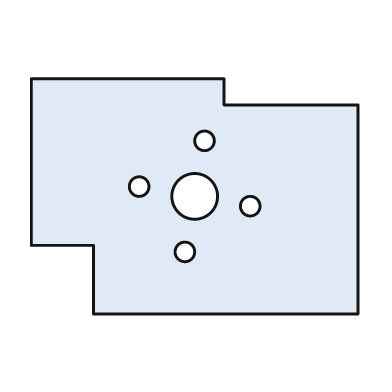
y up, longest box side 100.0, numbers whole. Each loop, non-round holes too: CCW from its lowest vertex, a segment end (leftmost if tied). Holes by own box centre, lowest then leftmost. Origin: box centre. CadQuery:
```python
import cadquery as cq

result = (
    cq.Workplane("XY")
    .moveTo(-31.0, -36.0)
    .lineTo(50.0, -36.0)
    .lineTo(50.0, 28.0)
    .lineTo(9.0, 28.0)
    .lineTo(9.0, 36.0)
    .lineTo(-50.0, 36.0)
    .lineTo(-50.0, -15.0)
    .lineTo(-31.0, -15.0)
    .close()
    .moveTo(-3.0, -17.0)
    .circle(3.0)
    .moveTo(17.0, -3.0)
    .circle(3.0)
    .moveTo(0.0, 0.0)
    .circle(7.0)
    .moveTo(-17.0, 3.0)
    .circle(3.0)
    .moveTo(3.0, 17.0)
    .circle(3.0)
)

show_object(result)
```